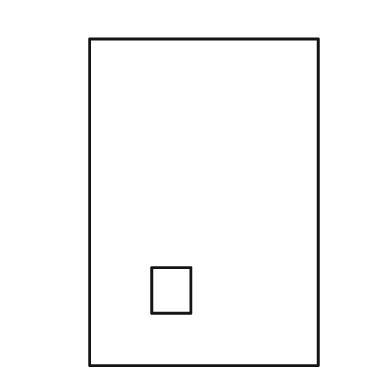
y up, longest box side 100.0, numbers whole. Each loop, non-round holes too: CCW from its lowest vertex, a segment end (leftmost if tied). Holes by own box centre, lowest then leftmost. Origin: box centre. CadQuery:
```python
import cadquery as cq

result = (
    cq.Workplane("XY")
    .moveTo(-35.0, -50.0)
    .lineTo(35.0, -50.0)
    .lineTo(35.0, 50.0)
    .lineTo(-35.0, 50.0)
    .close()
    .moveTo(-16.0, -34.0)
    .lineTo(-4.0, -34.0)
    .lineTo(-4.0, -20.0)
    .lineTo(-16.0, -20.0)
    .close()
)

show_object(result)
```